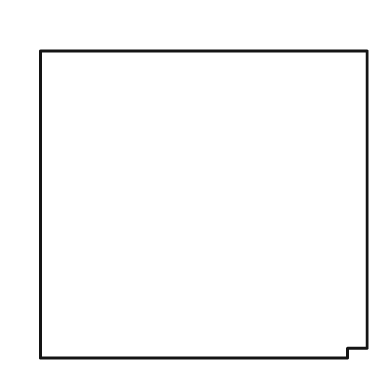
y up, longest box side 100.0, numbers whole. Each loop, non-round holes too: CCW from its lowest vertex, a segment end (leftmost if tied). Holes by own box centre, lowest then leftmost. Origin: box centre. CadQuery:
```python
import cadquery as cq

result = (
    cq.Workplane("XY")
    .moveTo(-50.0, -47.0)
    .lineTo(44.0, -47.0)
    .lineTo(44.0, -44.0)
    .lineTo(50.0, -44.0)
    .lineTo(50.0, 47.0)
    .lineTo(-50.0, 47.0)
    .close()
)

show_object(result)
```